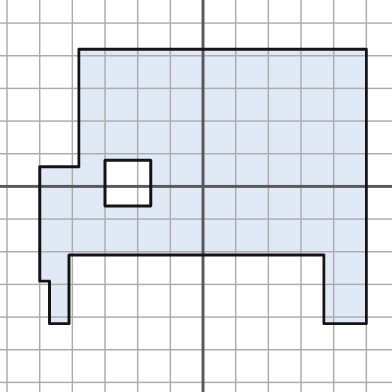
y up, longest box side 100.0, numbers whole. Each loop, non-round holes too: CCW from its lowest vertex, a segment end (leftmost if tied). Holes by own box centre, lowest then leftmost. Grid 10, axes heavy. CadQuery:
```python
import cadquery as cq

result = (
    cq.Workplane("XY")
    .moveTo(-47.0, -42.0)
    .lineTo(-41.0, -42.0)
    .lineTo(-41.0, -21.0)
    .lineTo(37.0, -21.0)
    .lineTo(37.0, -42.0)
    .lineTo(50.0, -42.0)
    .lineTo(50.0, 42.0)
    .lineTo(-38.0, 42.0)
    .lineTo(-38.0, 6.0)
    .lineTo(-50.0, 6.0)
    .lineTo(-50.0, -29.0)
    .lineTo(-47.0, -29.0)
    .close()
    .moveTo(-30.0, -6.0)
    .lineTo(-16.0, -6.0)
    .lineTo(-16.0, 8.0)
    .lineTo(-30.0, 8.0)
    .close()
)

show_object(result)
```